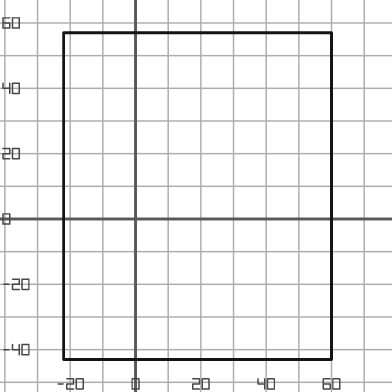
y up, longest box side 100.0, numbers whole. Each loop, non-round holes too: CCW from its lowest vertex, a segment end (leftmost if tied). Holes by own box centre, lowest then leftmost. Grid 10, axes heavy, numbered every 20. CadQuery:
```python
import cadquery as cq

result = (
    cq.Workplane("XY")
    .moveTo(-22.0, -43.0)
    .lineTo(60.0, -43.0)
    .lineTo(60.0, 57.0)
    .lineTo(-22.0, 57.0)
    .close()
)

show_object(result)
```